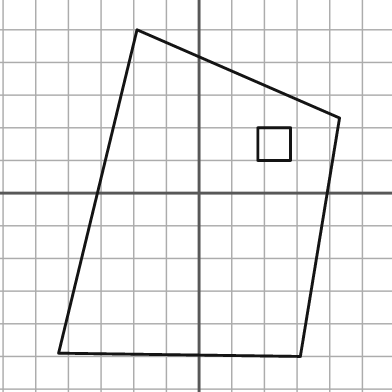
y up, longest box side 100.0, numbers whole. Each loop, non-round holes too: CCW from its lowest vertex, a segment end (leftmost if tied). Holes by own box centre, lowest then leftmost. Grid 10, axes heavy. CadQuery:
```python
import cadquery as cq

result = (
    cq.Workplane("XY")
    .moveTo(31.0, -50.0)
    .lineTo(43.0, 23.0)
    .lineTo(-19.0, 50.0)
    .lineTo(-43.0, -49.0)
    .close()
    .moveTo(18.0, 10.0)
    .lineTo(28.0, 10.0)
    .lineTo(28.0, 20.0)
    .lineTo(18.0, 20.0)
    .close()
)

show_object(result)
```